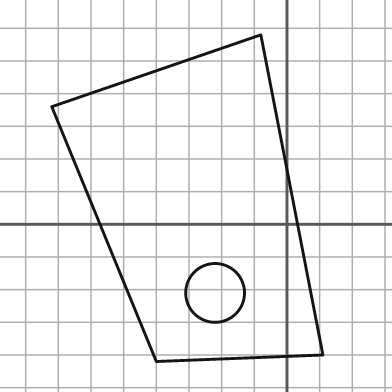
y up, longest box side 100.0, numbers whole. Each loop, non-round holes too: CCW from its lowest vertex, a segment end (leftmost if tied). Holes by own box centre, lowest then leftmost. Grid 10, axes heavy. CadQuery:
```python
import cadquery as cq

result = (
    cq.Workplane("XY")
    .moveTo(-40.0, -42.0)
    .lineTo(11.0, -40.0)
    .lineTo(-8.0, 58.0)
    .lineTo(-72.0, 36.0)
    .close()
    .moveTo(-22.0, -21.0)
    .circle(9.0)
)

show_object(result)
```